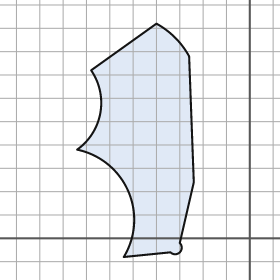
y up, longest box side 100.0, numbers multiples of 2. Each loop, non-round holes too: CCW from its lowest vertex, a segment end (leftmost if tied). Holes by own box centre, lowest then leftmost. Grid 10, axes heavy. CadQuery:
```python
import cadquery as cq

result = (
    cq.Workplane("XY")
    .moveTo(-54.0, -8.0)
    .lineTo(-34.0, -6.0)
    .threePointArc((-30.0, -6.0), (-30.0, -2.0))
    .lineTo(-24.0, 24.0)
    .lineTo(-26.0, 78.0)
    .threePointArc((-32.0, 86.0), (-40.0, 92.0))
    .lineTo(-68.0, 72.0)
    .threePointArc((-64.0, 54.0), (-74.0, 38.0))
    .threePointArc((-52.0, 20.0), (-54.0, -8.0))
    .close()
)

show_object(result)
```